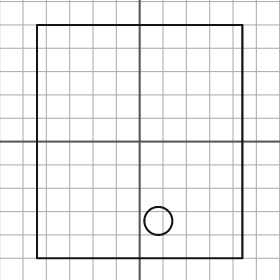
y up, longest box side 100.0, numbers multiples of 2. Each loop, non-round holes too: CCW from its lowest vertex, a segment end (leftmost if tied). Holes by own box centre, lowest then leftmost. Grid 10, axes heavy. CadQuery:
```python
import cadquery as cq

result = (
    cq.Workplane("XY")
    .moveTo(-44.0, -50.0)
    .lineTo(44.0, -50.0)
    .lineTo(44.0, 50.0)
    .lineTo(-44.0, 50.0)
    .close()
    .moveTo(8.0, -34.0)
    .circle(6.0)
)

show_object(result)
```